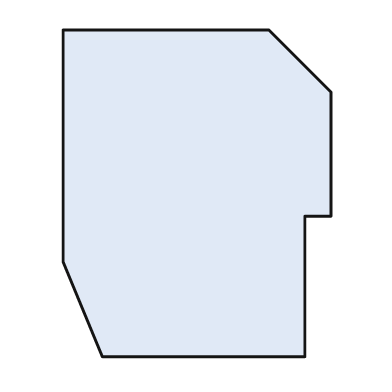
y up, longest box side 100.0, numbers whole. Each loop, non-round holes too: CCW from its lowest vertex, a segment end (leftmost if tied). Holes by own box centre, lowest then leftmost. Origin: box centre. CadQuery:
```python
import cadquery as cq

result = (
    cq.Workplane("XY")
    .moveTo(-29.0, -50.0)
    .lineTo(33.0, -50.0)
    .lineTo(33.0, -7.0)
    .lineTo(41.0, -7.0)
    .lineTo(41.0, 31.0)
    .lineTo(22.0, 50.0)
    .lineTo(-41.0, 50.0)
    .lineTo(-41.0, -21.0)
    .close()
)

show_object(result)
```